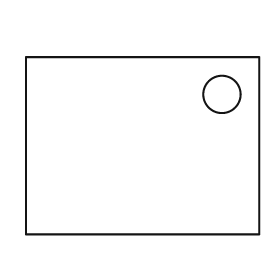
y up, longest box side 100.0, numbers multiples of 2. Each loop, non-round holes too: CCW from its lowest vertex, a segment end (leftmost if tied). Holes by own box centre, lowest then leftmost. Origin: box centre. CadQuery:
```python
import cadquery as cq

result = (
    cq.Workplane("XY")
    .moveTo(-50.0, -38.0)
    .lineTo(50.0, -38.0)
    .lineTo(50.0, 38.0)
    .lineTo(-50.0, 38.0)
    .close()
    .moveTo(34.0, 22.0)
    .circle(8.0)
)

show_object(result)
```